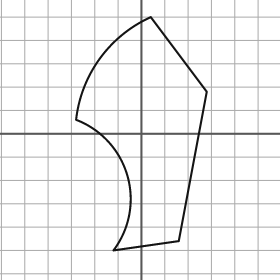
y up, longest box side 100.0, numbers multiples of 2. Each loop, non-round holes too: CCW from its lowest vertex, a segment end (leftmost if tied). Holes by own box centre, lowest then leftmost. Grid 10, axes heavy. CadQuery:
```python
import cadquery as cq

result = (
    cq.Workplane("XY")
    .moveTo(-12.0, -50.0)
    .lineTo(16.0, -46.0)
    .lineTo(28.0, 18.0)
    .lineTo(4.0, 50.0)
    .threePointArc((-18.0, 32.0), (-28.0, 6.0))
    .threePointArc((-6.0, -18.0), (-12.0, -50.0))
    .close()
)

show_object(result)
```